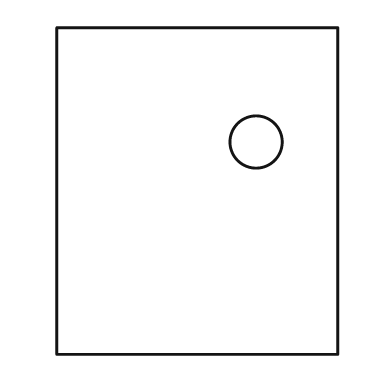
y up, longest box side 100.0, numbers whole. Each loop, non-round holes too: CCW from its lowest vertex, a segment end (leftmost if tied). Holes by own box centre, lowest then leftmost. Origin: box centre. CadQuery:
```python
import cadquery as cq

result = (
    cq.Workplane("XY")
    .moveTo(-43.0, -50.0)
    .lineTo(43.0, -50.0)
    .lineTo(43.0, 50.0)
    .lineTo(-43.0, 50.0)
    .close()
    .moveTo(18.0, 15.0)
    .circle(8.0)
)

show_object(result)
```